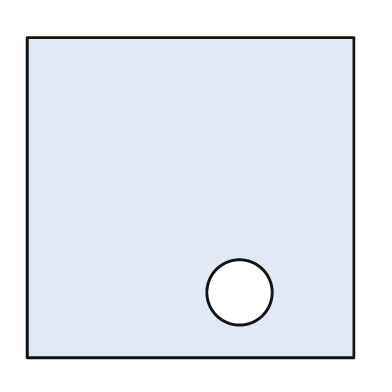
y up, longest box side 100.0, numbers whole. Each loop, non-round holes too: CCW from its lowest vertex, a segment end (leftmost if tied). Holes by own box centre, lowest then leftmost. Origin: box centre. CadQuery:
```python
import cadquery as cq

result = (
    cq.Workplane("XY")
    .moveTo(-50.0, -49.0)
    .lineTo(50.0, -49.0)
    .lineTo(50.0, 49.0)
    .lineTo(-50.0, 49.0)
    .close()
    .moveTo(15.0, -29.0)
    .circle(10.0)
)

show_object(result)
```